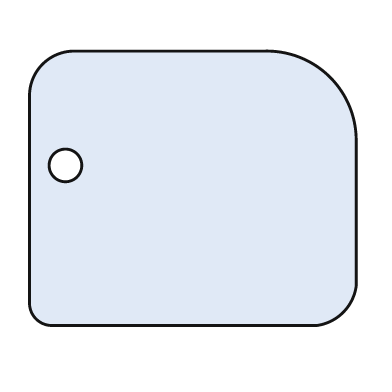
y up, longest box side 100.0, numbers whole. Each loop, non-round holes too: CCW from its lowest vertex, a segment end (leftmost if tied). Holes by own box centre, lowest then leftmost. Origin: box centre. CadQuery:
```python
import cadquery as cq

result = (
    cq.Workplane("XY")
    .moveTo(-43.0, -42.0)
    .lineTo(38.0, -42.0)
    .threePointArc((46.0, -38.0), (50.0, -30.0))
    .lineTo(50.0, 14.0)
    .threePointArc((42.0, 34.0), (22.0, 42.0))
    .lineTo(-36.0, 42.0)
    .threePointArc((-46.0, 38.0), (-50.0, 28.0))
    .lineTo(-50.0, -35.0)
    .threePointArc((-48.0, -40.0), (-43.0, -42.0))
    .close()
    .moveTo(-39.0, 7.0)
    .circle(5.0)
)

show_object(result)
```